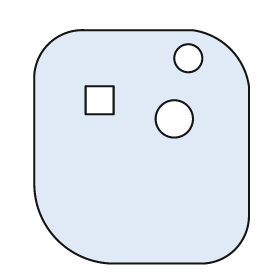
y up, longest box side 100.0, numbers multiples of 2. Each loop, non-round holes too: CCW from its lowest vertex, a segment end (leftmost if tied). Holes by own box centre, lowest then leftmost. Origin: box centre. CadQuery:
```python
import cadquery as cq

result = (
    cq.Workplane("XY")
    .moveTo(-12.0, -50.0)
    .lineTo(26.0, -50.0)
    .threePointArc((40.0, -44.0), (46.0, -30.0))
    .lineTo(46.0, 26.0)
    .threePointArc((38.0, 42.0), (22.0, 50.0))
    .lineTo(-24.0, 50.0)
    .threePointArc((-40.0, 44.0), (-46.0, 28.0))
    .lineTo(-46.0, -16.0)
    .threePointArc((-36.0, -40.0), (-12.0, -50.0))
    .close()
    .moveTo(14.0, 12.0)
    .circle(8.0)
    .moveTo(-24.0, 14.0)
    .lineTo(-12.0, 14.0)
    .lineTo(-12.0, 26.0)
    .lineTo(-24.0, 26.0)
    .close()
    .moveTo(20.0, 38.0)
    .circle(6.0)
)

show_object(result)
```